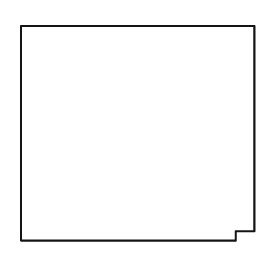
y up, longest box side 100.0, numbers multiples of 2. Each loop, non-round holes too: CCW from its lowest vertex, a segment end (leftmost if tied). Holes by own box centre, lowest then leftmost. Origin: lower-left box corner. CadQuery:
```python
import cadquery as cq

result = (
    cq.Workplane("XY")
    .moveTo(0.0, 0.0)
    .lineTo(92.0, 0.0)
    .lineTo(92.0, 4.0)
    .lineTo(100.0, 4.0)
    .lineTo(100.0, 92.0)
    .lineTo(0.0, 92.0)
    .close()
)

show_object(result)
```